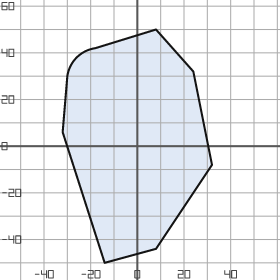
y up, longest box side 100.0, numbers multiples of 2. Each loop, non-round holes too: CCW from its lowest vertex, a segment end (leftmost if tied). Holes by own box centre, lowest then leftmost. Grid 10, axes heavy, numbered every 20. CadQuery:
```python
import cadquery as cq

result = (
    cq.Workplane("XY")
    .moveTo(-14.0, -50.0)
    .lineTo(8.0, -44.0)
    .lineTo(32.0, -8.0)
    .lineTo(24.0, 32.0)
    .lineTo(8.0, 50.0)
    .lineTo(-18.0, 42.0)
    .threePointArc((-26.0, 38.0), (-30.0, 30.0))
    .lineTo(-32.0, 6.0)
    .close()
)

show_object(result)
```